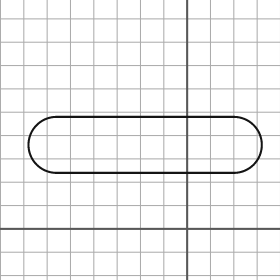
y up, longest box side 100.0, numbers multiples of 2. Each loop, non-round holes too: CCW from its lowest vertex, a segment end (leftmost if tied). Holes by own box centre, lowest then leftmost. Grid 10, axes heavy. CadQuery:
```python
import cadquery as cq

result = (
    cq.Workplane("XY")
    .moveTo(-56.0, 24.0)
    .lineTo(20.0, 24.0)
    .threePointArc((32.0, 36.0), (20.0, 48.0))
    .lineTo(-56.0, 48.0)
    .threePointArc((-68.0, 36.0), (-56.0, 24.0))
    .close()
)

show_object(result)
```